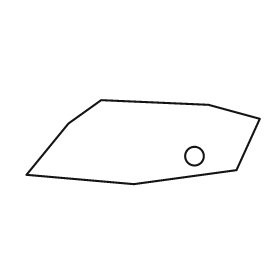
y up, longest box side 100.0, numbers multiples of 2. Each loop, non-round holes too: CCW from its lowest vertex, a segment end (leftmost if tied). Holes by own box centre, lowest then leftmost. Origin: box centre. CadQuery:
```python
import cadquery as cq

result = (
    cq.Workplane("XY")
    .moveTo(-4.0, -18.0)
    .lineTo(40.0, -12.0)
    .lineTo(50.0, 10.0)
    .lineTo(28.0, 16.0)
    .lineTo(-18.0, 18.0)
    .lineTo(-32.0, 8.0)
    .lineTo(-50.0, -14.0)
    .close()
    .moveTo(22.0, -6.0)
    .circle(4.0)
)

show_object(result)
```